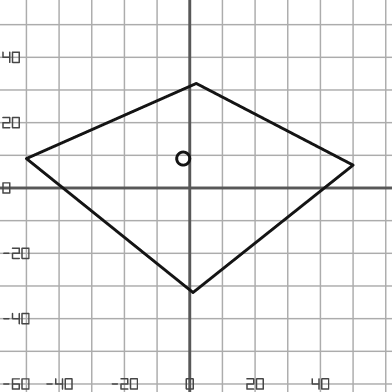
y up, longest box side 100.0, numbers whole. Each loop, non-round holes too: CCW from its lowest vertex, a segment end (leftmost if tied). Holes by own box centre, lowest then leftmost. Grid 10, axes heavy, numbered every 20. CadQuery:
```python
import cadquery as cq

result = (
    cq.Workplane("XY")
    .moveTo(1.0, -32.0)
    .lineTo(50.0, 7.0)
    .lineTo(2.0, 32.0)
    .lineTo(-50.0, 9.0)
    .close()
    .moveTo(-2.0, 9.0)
    .circle(2.0)
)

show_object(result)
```